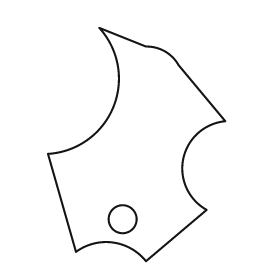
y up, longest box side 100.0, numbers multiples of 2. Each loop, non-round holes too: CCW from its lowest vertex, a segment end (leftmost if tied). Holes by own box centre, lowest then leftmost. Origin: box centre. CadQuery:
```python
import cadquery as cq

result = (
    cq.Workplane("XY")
    .moveTo(4.0, -50.0)
    .lineTo(30.0, -28.0)
    .threePointArc((20.0, -6.0), (38.0, 10.0))
    .lineTo(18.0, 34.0)
    .threePointArc((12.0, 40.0), (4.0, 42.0))
    .lineTo(-16.0, 50.0)
    .threePointArc((-10.0, 16.0), (-38.0, -4.0))
    .lineTo(-26.0, -46.0)
    .threePointArc((-10.0, -42.0), (4.0, -50.0))
    .close()
    .moveTo(-6.0, -32.0)
    .circle(6.0)
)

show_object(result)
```